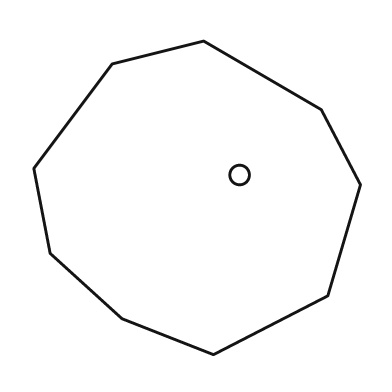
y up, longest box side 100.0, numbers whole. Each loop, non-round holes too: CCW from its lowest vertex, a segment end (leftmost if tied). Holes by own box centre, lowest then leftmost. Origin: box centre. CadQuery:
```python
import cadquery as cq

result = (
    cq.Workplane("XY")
    .moveTo(5.0, -48.0)
    .lineTo(40.0, -30.0)
    .lineTo(50.0, 4.0)
    .lineTo(38.0, 27.0)
    .lineTo(2.0, 48.0)
    .lineTo(-26.0, 41.0)
    .lineTo(-50.0, 9.0)
    .lineTo(-45.0, -17.0)
    .lineTo(-23.0, -37.0)
    .close()
    .moveTo(13.0, 7.0)
    .circle(3.0)
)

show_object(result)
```